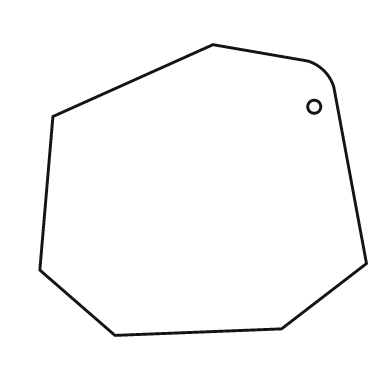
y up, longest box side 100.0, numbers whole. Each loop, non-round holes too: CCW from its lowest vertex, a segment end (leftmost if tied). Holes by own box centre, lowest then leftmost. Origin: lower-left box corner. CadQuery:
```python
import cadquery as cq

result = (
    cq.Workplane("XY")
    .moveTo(23.0, 0.0)
    .lineTo(74.0, 2.0)
    .lineTo(100.0, 22.0)
    .lineTo(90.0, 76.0)
    .threePointArc((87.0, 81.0), (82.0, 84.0))
    .lineTo(53.0, 89.0)
    .lineTo(4.0, 67.0)
    .lineTo(0.0, 20.0)
    .close()
    .moveTo(84.0, 70.0)
    .circle(2.0)
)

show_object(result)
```